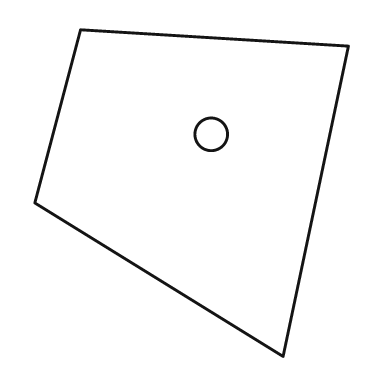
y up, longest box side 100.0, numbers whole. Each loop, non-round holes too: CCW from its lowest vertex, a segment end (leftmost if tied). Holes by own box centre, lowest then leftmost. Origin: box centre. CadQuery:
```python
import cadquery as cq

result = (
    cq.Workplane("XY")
    .moveTo(28.0, -50.0)
    .lineTo(48.0, 45.0)
    .lineTo(-34.0, 50.0)
    .lineTo(-48.0, -3.0)
    .close()
    .moveTo(6.0, 18.0)
    .circle(5.0)
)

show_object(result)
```